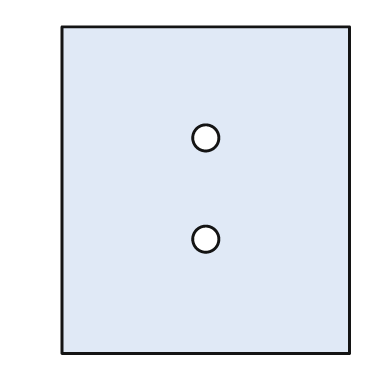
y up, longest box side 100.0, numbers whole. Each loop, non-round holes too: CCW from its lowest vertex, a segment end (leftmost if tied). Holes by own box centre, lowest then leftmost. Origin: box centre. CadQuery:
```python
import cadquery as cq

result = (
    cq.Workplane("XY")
    .moveTo(-44.0, -50.0)
    .lineTo(44.0, -50.0)
    .lineTo(44.0, 50.0)
    .lineTo(-44.0, 50.0)
    .close()
    .moveTo(0.0, -15.0)
    .circle(4.0)
    .moveTo(0.0, 16.0)
    .circle(4.0)
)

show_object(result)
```